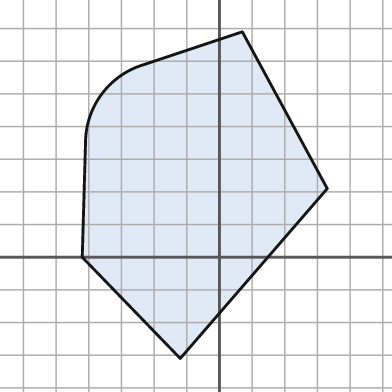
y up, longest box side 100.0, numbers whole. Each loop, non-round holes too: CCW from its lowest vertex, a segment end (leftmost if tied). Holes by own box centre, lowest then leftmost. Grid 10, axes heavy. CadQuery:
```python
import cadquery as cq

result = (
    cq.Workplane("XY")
    .moveTo(-12.0, -31.0)
    .lineTo(33.0, 21.0)
    .lineTo(7.0, 69.0)
    .lineTo(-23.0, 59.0)
    .threePointArc((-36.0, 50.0), (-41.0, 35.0))
    .lineTo(-42.0, 0.0)
    .close()
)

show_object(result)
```